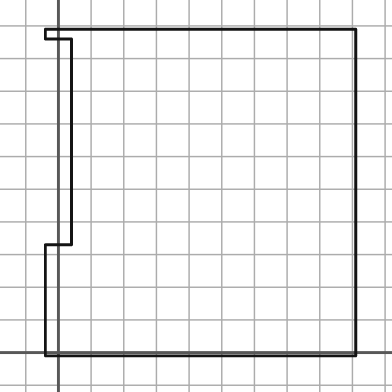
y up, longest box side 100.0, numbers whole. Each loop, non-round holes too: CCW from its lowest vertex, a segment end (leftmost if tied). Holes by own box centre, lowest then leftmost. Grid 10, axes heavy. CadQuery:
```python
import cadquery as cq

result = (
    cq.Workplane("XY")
    .moveTo(-4.0, -1.0)
    .lineTo(91.0, -1.0)
    .lineTo(91.0, 99.0)
    .lineTo(-4.0, 99.0)
    .lineTo(-4.0, 96.0)
    .lineTo(4.0, 96.0)
    .lineTo(4.0, 33.0)
    .lineTo(-4.0, 33.0)
    .close()
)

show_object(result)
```